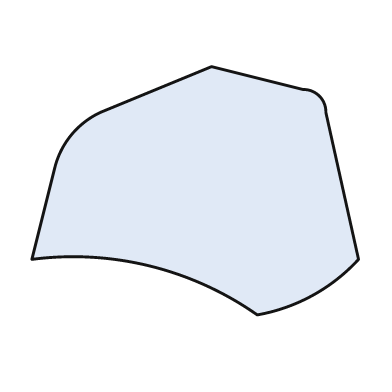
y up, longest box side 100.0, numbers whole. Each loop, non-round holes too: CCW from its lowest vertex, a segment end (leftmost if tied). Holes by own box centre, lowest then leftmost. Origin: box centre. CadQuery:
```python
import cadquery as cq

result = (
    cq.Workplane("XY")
    .moveTo(19.0, -38.0)
    .threePointArc((36.0, -32.0), (50.0, -21.0))
    .lineTo(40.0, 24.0)
    .threePointArc((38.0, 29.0), (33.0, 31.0))
    .lineTo(5.0, 38.0)
    .lineTo(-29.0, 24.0)
    .threePointArc((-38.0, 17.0), (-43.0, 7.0))
    .lineTo(-50.0, -21.0)
    .threePointArc((-14.0, -23.0), (19.0, -38.0))
    .close()
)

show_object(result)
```